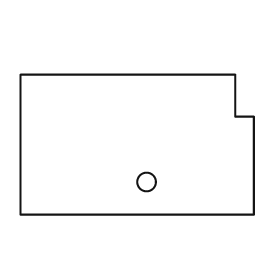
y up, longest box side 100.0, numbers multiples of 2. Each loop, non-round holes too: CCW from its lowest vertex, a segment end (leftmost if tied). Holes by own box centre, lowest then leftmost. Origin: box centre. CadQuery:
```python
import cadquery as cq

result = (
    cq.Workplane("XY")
    .moveTo(-50.0, -30.0)
    .lineTo(50.0, -30.0)
    .lineTo(50.0, 12.0)
    .lineTo(42.0, 12.0)
    .lineTo(42.0, 30.0)
    .lineTo(-50.0, 30.0)
    .close()
    .moveTo(4.0, -16.0)
    .circle(4.0)
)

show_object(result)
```